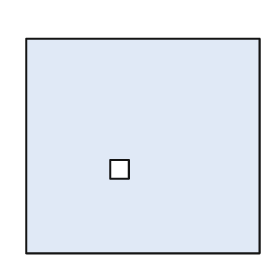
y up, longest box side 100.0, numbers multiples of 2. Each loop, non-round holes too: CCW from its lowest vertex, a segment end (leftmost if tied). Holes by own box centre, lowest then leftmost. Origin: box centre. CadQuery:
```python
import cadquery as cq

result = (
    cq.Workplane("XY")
    .moveTo(-50.0, -46.0)
    .lineTo(50.0, -46.0)
    .lineTo(50.0, 46.0)
    .lineTo(-50.0, 46.0)
    .close()
    .moveTo(-14.0, -14.0)
    .lineTo(-6.0, -14.0)
    .lineTo(-6.0, -6.0)
    .lineTo(-14.0, -6.0)
    .close()
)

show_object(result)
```